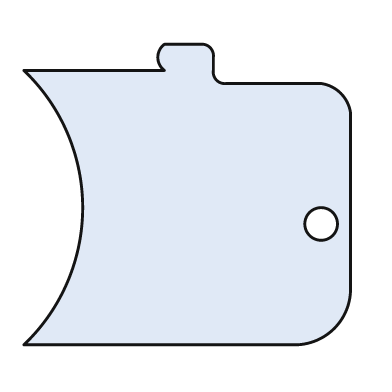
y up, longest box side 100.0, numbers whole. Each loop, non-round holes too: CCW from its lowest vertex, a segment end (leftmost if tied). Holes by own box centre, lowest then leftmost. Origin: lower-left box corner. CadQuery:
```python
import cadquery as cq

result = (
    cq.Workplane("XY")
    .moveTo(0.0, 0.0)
    .lineTo(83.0, 0.0)
    .threePointArc((95.0, 5.0), (100.0, 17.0))
    .lineTo(100.0, 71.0)
    .threePointArc((97.0, 77.0), (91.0, 80.0))
    .lineTo(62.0, 80.0)
    .threePointArc((59.0, 81.0), (58.0, 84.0))
    .lineTo(58.0, 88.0)
    .threePointArc((57.0, 91.0), (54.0, 92.0))
    .lineTo(43.0, 92.0)
    .threePointArc((41.0, 88.0), (43.0, 84.0))
    .lineTo(0.0, 84.0)
    .threePointArc((18.0, 42.0), (0.0, 0.0))
    .close()
    .moveTo(91.0, 37.0)
    .circle(5.0)
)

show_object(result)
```